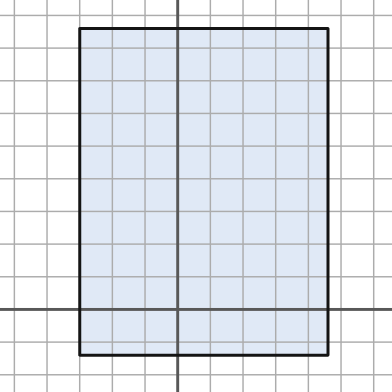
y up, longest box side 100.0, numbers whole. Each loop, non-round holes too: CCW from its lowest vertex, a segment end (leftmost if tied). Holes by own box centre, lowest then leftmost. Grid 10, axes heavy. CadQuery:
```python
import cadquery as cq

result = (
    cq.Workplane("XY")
    .moveTo(-30.0, -14.0)
    .lineTo(46.0, -14.0)
    .lineTo(46.0, 86.0)
    .lineTo(-30.0, 86.0)
    .close()
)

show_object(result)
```